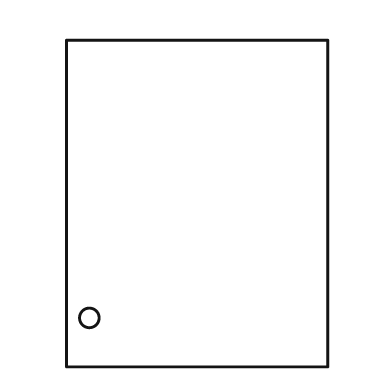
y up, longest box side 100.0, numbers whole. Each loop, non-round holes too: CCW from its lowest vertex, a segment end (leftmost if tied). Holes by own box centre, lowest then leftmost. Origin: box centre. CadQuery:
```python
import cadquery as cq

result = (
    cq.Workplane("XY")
    .moveTo(-40.0, -50.0)
    .lineTo(40.0, -50.0)
    .lineTo(40.0, 50.0)
    .lineTo(-40.0, 50.0)
    .close()
    .moveTo(-33.0, -35.0)
    .circle(3.0)
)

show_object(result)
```